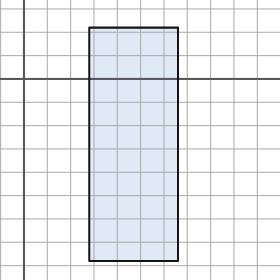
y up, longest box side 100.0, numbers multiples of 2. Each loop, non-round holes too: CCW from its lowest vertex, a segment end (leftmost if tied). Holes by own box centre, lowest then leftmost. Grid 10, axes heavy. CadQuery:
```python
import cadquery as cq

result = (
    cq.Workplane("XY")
    .moveTo(28.0, -78.0)
    .lineTo(66.0, -78.0)
    .lineTo(66.0, 22.0)
    .lineTo(28.0, 22.0)
    .close()
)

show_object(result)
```